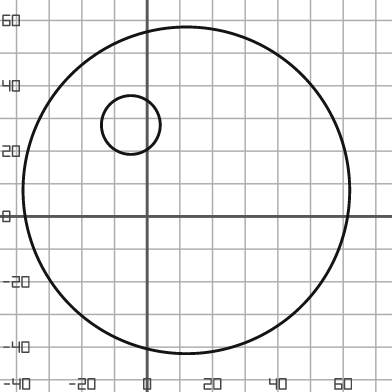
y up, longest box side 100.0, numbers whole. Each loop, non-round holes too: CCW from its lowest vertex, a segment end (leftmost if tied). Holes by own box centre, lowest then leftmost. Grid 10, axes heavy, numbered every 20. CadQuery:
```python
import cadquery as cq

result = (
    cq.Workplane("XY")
    .moveTo(12.0, 8.0)
    .circle(50.0)
    .moveTo(-5.0, 28.0)
    .circle(9.0)
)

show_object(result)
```